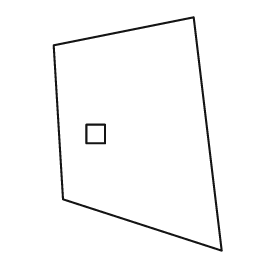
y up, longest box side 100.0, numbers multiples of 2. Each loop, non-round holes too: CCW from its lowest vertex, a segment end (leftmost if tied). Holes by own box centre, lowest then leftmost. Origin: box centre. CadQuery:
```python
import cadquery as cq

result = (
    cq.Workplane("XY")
    .moveTo(36.0, -50.0)
    .lineTo(24.0, 50.0)
    .lineTo(-36.0, 38.0)
    .lineTo(-32.0, -28.0)
    .close()
    .moveTo(-22.0, -4.0)
    .lineTo(-14.0, -4.0)
    .lineTo(-14.0, 4.0)
    .lineTo(-22.0, 4.0)
    .close()
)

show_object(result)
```